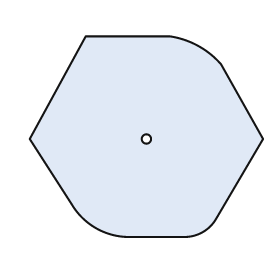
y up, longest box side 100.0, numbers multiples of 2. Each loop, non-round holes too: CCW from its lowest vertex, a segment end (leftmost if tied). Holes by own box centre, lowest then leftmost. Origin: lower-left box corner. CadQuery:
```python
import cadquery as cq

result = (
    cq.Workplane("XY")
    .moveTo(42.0, 0.0)
    .lineTo(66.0, 0.0)
    .threePointArc((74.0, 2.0), (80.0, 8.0))
    .lineTo(100.0, 42.0)
    .lineTo(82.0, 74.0)
    .threePointArc((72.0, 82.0), (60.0, 86.0))
    .lineTo(24.0, 86.0)
    .lineTo(0.0, 42.0)
    .lineTo(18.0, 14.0)
    .threePointArc((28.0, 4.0), (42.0, 0.0))
    .close()
    .moveTo(50.0, 42.0)
    .circle(2.0)
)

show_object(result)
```